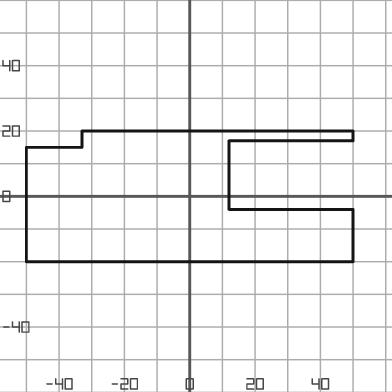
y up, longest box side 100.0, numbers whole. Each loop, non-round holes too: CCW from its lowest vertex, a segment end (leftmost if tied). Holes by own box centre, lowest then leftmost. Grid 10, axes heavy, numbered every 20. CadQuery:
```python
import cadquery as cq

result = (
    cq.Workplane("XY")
    .moveTo(-50.0, -20.0)
    .lineTo(50.0, -20.0)
    .lineTo(50.0, -4.0)
    .lineTo(12.0, -4.0)
    .lineTo(12.0, 17.0)
    .lineTo(50.0, 17.0)
    .lineTo(50.0, 20.0)
    .lineTo(-33.0, 20.0)
    .lineTo(-33.0, 15.0)
    .lineTo(-50.0, 15.0)
    .close()
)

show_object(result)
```